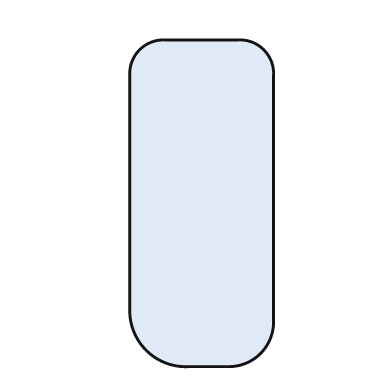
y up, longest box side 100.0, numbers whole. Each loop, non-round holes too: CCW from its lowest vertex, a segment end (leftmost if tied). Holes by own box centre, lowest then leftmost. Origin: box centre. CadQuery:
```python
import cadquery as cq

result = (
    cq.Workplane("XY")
    .moveTo(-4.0, -50.0)
    .lineTo(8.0, -50.0)
    .threePointArc((18.0, -46.0), (22.0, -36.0))
    .lineTo(22.0, 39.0)
    .threePointArc((19.0, 47.0), (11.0, 50.0))
    .lineTo(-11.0, 50.0)
    .threePointArc((-19.0, 47.0), (-22.0, 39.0))
    .lineTo(-22.0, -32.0)
    .threePointArc((-17.0, -45.0), (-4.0, -50.0))
    .close()
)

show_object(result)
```